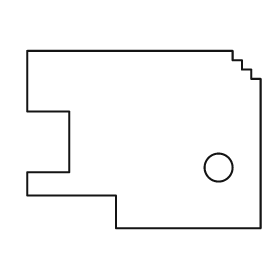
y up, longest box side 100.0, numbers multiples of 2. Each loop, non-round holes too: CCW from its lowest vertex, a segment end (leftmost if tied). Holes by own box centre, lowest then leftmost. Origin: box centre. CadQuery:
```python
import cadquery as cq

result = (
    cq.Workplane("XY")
    .moveTo(-12.0, -38.0)
    .lineTo(50.0, -38.0)
    .lineTo(50.0, 26.0)
    .lineTo(46.0, 26.0)
    .lineTo(46.0, 30.0)
    .lineTo(42.0, 30.0)
    .lineTo(42.0, 34.0)
    .lineTo(38.0, 34.0)
    .lineTo(38.0, 38.0)
    .lineTo(-50.0, 38.0)
    .lineTo(-50.0, 12.0)
    .lineTo(-32.0, 12.0)
    .lineTo(-32.0, -14.0)
    .lineTo(-50.0, -14.0)
    .lineTo(-50.0, -24.0)
    .lineTo(-12.0, -24.0)
    .close()
    .moveTo(32.0, -12.0)
    .circle(6.0)
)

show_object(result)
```